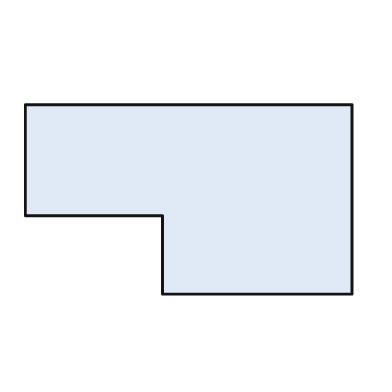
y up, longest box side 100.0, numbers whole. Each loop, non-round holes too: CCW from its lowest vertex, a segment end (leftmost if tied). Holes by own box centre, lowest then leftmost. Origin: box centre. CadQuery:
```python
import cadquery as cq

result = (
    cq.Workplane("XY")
    .moveTo(-8.0, -29.0)
    .lineTo(50.0, -29.0)
    .lineTo(50.0, 29.0)
    .lineTo(-50.0, 29.0)
    .lineTo(-50.0, -5.0)
    .lineTo(-8.0, -5.0)
    .close()
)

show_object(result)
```